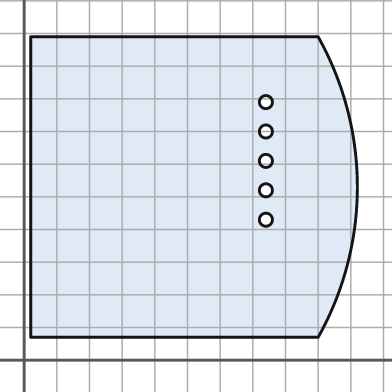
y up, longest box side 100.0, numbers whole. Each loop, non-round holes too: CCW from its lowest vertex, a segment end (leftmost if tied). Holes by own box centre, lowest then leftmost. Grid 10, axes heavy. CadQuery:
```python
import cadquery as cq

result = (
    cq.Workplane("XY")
    .moveTo(2.0, 7.0)
    .lineTo(90.0, 7.0)
    .threePointArc((102.0, 53.0), (90.0, 99.0))
    .lineTo(2.0, 99.0)
    .close()
    .moveTo(74.0, 43.0)
    .circle(2.0)
    .moveTo(74.0, 52.0)
    .circle(2.0)
    .moveTo(74.0, 61.0)
    .circle(2.0)
    .moveTo(74.0, 70.0)
    .circle(2.0)
    .moveTo(74.0, 79.0)
    .circle(2.0)
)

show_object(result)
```